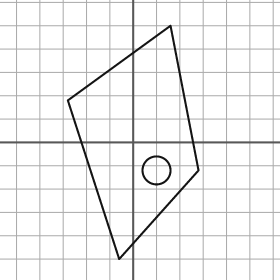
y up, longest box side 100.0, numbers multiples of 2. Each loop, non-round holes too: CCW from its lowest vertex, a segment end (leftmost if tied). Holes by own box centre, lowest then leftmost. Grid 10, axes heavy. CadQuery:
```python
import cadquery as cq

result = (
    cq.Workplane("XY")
    .moveTo(-6.0, -50.0)
    .lineTo(28.0, -12.0)
    .lineTo(16.0, 50.0)
    .lineTo(-28.0, 18.0)
    .close()
    .moveTo(10.0, -12.0)
    .circle(6.0)
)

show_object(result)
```